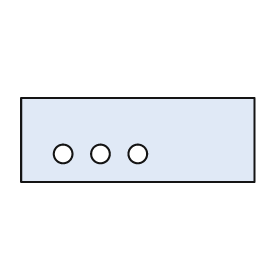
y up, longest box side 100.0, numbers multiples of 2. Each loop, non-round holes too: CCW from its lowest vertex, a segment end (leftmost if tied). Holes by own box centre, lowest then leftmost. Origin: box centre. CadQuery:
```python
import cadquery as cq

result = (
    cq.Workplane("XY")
    .moveTo(-50.0, -18.0)
    .lineTo(50.0, -18.0)
    .lineTo(50.0, 18.0)
    .lineTo(-50.0, 18.0)
    .close()
    .moveTo(-32.0, -6.0)
    .circle(4.0)
    .moveTo(-16.0, -6.0)
    .circle(4.0)
    .moveTo(0.0, -6.0)
    .circle(4.0)
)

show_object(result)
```